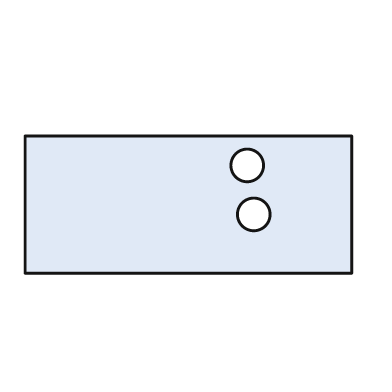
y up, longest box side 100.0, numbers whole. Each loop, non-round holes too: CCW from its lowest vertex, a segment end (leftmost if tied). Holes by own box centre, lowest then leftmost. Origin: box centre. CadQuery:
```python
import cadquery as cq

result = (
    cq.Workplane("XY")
    .moveTo(-50.0, -21.0)
    .lineTo(50.0, -21.0)
    .lineTo(50.0, 21.0)
    .lineTo(-50.0, 21.0)
    .close()
    .moveTo(20.0, -3.0)
    .circle(5.0)
    .moveTo(18.0, 12.0)
    .circle(5.0)
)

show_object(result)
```